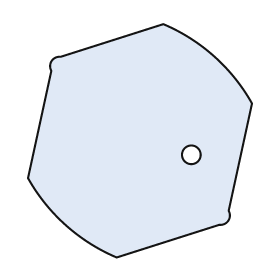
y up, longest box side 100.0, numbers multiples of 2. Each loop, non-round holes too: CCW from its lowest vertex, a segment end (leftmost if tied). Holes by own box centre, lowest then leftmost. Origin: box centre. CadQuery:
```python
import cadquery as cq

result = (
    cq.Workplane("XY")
    .moveTo(-10.0, -50.0)
    .lineTo(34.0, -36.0)
    .threePointArc((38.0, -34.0), (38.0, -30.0))
    .lineTo(48.0, 16.0)
    .threePointArc((32.0, 36.0), (10.0, 50.0))
    .lineTo(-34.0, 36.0)
    .threePointArc((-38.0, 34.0), (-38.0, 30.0))
    .lineTo(-48.0, -16.0)
    .threePointArc((-32.0, -36.0), (-10.0, -50.0))
    .close()
    .moveTo(22.0, -6.0)
    .circle(4.0)
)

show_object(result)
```